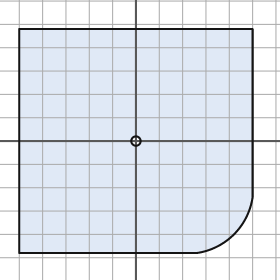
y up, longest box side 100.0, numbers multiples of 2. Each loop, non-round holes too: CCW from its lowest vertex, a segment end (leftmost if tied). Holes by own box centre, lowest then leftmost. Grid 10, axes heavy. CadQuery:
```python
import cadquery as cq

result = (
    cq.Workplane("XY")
    .moveTo(-50.0, -48.0)
    .lineTo(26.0, -48.0)
    .threePointArc((42.0, -40.0), (50.0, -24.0))
    .lineTo(50.0, 48.0)
    .lineTo(-50.0, 48.0)
    .close()
    .moveTo(0.0, 0.0)
    .circle(2.0)
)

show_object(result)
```